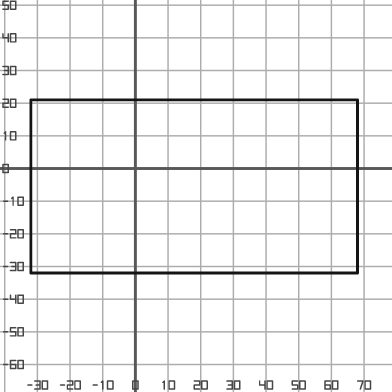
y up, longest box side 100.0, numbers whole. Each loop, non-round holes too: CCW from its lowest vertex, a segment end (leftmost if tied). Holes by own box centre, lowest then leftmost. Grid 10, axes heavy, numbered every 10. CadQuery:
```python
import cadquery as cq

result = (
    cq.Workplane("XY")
    .moveTo(-32.0, -32.0)
    .lineTo(68.0, -32.0)
    .lineTo(68.0, 21.0)
    .lineTo(-32.0, 21.0)
    .close()
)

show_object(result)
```